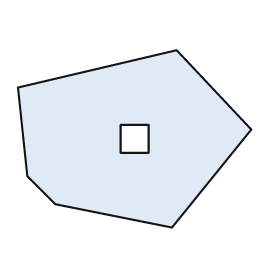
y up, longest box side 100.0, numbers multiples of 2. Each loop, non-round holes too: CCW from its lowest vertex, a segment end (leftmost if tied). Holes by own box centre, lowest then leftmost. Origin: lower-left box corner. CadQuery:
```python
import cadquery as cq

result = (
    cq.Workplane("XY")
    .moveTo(66.0, 0.0)
    .lineTo(100.0, 42.0)
    .lineTo(68.0, 76.0)
    .lineTo(0.0, 60.0)
    .lineTo(4.0, 22.0)
    .lineTo(16.0, 10.0)
    .close()
    .moveTo(44.0, 32.0)
    .lineTo(56.0, 32.0)
    .lineTo(56.0, 44.0)
    .lineTo(44.0, 44.0)
    .close()
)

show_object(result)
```